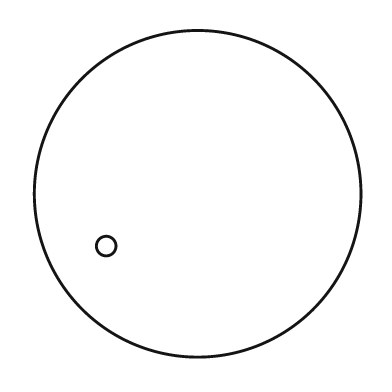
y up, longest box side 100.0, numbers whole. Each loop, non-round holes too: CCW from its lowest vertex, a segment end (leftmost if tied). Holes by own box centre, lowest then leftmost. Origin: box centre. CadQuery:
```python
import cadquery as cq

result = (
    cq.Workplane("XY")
    .moveTo(0.0, 0.0)
    .circle(50.0)
    .moveTo(-28.0, -16.0)
    .circle(3.0)
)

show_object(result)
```